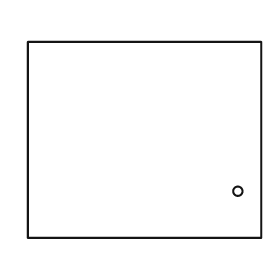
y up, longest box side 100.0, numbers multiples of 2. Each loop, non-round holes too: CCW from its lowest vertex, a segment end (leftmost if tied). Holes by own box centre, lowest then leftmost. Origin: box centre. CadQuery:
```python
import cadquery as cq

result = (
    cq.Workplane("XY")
    .moveTo(-50.0, -42.0)
    .lineTo(50.0, -42.0)
    .lineTo(50.0, 42.0)
    .lineTo(-50.0, 42.0)
    .close()
    .moveTo(40.0, -22.0)
    .circle(2.0)
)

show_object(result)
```